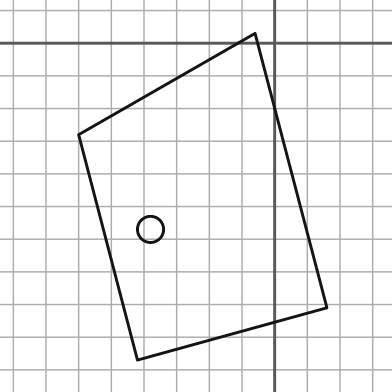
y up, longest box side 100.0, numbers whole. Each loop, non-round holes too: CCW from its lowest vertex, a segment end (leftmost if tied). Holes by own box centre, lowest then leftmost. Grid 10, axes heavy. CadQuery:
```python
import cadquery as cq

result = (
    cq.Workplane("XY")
    .moveTo(-42.0, -97.0)
    .lineTo(16.0, -81.0)
    .lineTo(-6.0, 3.0)
    .lineTo(-60.0, -28.0)
    .close()
    .moveTo(-38.0, -57.0)
    .circle(4.0)
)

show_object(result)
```